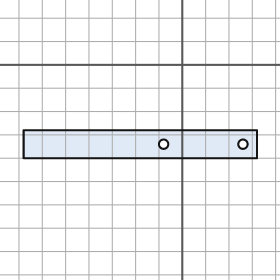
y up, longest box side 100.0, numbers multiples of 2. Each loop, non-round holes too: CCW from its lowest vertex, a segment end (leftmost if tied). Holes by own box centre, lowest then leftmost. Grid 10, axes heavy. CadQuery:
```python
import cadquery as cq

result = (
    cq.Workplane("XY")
    .moveTo(-68.0, -40.0)
    .lineTo(32.0, -40.0)
    .lineTo(32.0, -28.0)
    .lineTo(-68.0, -28.0)
    .close()
    .moveTo(-8.0, -34.0)
    .circle(2.0)
    .moveTo(26.0, -34.0)
    .circle(2.0)
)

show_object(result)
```